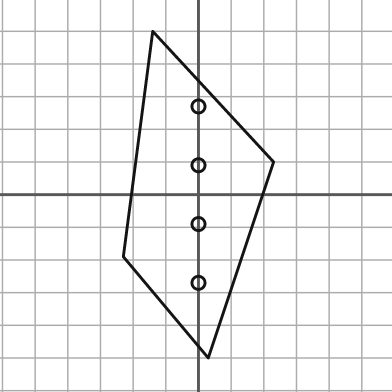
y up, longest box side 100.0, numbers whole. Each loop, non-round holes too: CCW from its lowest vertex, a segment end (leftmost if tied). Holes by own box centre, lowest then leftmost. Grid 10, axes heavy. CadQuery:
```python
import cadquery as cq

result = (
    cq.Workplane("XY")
    .moveTo(3.0, -50.0)
    .lineTo(23.0, 10.0)
    .lineTo(-14.0, 50.0)
    .lineTo(-23.0, -19.0)
    .close()
    .moveTo(0.0, -27.0)
    .circle(2.0)
    .moveTo(0.0, -9.0)
    .circle(2.0)
    .moveTo(0.0, 9.0)
    .circle(2.0)
    .moveTo(0.0, 27.0)
    .circle(2.0)
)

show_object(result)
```